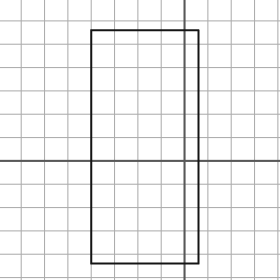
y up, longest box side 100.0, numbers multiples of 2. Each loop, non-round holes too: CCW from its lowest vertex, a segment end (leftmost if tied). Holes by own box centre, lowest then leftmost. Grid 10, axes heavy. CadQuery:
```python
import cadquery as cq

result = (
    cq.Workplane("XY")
    .moveTo(-40.0, -44.0)
    .lineTo(6.0, -44.0)
    .lineTo(6.0, 56.0)
    .lineTo(-40.0, 56.0)
    .close()
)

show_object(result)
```